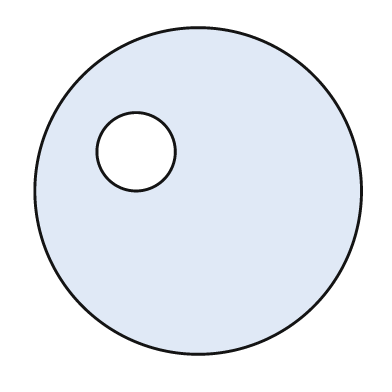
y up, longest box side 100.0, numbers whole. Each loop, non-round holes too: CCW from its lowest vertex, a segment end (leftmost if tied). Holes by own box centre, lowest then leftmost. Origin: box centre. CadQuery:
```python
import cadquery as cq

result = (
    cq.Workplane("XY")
    .moveTo(0.0, 0.0)
    .circle(50.0)
    .moveTo(-19.0, 12.0)
    .circle(12.0)
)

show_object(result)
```